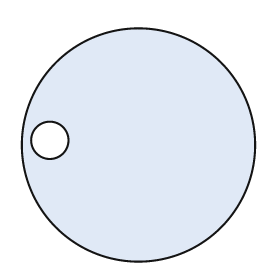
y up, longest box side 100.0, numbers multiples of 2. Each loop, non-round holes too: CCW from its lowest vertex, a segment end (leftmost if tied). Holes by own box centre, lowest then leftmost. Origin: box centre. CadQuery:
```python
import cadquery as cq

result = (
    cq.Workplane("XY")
    .moveTo(0.0, 0.0)
    .circle(50.0)
    .moveTo(-38.0, 2.0)
    .circle(8.0)
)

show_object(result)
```